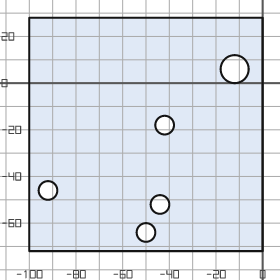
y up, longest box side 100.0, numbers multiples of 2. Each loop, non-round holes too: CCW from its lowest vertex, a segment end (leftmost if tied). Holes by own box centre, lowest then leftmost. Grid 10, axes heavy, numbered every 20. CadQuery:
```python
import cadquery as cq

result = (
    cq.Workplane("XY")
    .moveTo(-100.0, -72.0)
    .lineTo(0.0, -72.0)
    .lineTo(0.0, 28.0)
    .lineTo(-100.0, 28.0)
    .close()
    .moveTo(-50.0, -64.0)
    .circle(4.0)
    .moveTo(-44.0, -52.0)
    .circle(4.0)
    .moveTo(-92.0, -46.0)
    .circle(4.0)
    .moveTo(-42.0, -18.0)
    .circle(4.0)
    .moveTo(-12.0, 6.0)
    .circle(6.0)
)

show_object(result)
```